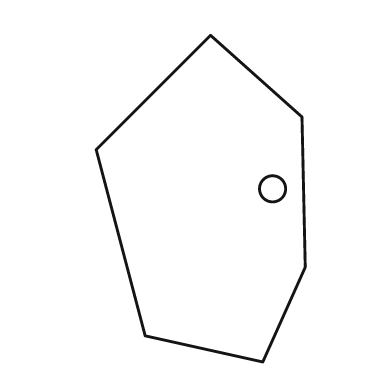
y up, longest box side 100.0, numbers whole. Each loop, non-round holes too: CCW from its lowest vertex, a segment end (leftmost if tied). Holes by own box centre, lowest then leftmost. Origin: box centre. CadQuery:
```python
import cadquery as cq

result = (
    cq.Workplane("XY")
    .moveTo(19.0, -50.0)
    .lineTo(32.0, -21.0)
    .lineTo(31.0, 25.0)
    .lineTo(3.0, 50.0)
    .lineTo(-32.0, 15.0)
    .lineTo(-17.0, -42.0)
    .close()
    .moveTo(22.0, 3.0)
    .circle(4.0)
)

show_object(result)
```